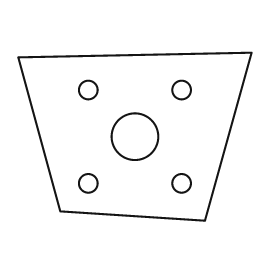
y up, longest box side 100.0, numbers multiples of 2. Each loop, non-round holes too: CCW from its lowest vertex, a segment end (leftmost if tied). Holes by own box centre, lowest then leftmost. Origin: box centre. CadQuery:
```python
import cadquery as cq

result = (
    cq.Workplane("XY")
    .moveTo(30.0, -36.0)
    .lineTo(50.0, 36.0)
    .lineTo(-50.0, 34.0)
    .lineTo(-32.0, -32.0)
    .close()
    .moveTo(-20.0, -20.0)
    .circle(4.0)
    .moveTo(20.0, -20.0)
    .circle(4.0)
    .moveTo(0.0, 0.0)
    .circle(10.0)
    .moveTo(-20.0, 20.0)
    .circle(4.0)
    .moveTo(20.0, 20.0)
    .circle(4.0)
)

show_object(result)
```